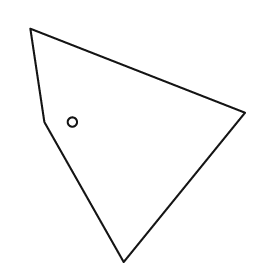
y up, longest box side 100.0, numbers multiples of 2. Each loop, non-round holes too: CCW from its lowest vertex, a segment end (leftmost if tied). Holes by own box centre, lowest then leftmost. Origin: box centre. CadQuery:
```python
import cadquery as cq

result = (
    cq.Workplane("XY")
    .moveTo(-6.0, -50.0)
    .lineTo(46.0, 14.0)
    .lineTo(-46.0, 50.0)
    .lineTo(-40.0, 10.0)
    .close()
    .moveTo(-28.0, 10.0)
    .circle(2.0)
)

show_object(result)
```